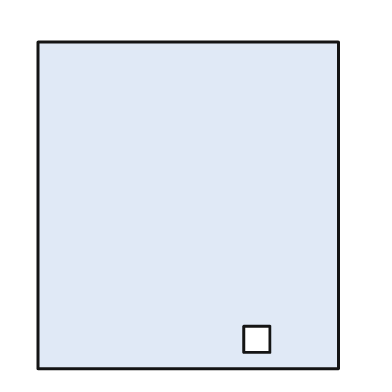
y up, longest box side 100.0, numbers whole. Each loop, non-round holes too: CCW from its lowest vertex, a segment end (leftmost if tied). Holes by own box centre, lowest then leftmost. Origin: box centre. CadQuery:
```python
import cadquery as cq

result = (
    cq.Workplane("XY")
    .moveTo(-46.0, -50.0)
    .lineTo(46.0, -50.0)
    .lineTo(46.0, 50.0)
    .lineTo(-46.0, 50.0)
    .close()
    .moveTo(17.0, -45.0)
    .lineTo(25.0, -45.0)
    .lineTo(25.0, -37.0)
    .lineTo(17.0, -37.0)
    .close()
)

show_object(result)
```